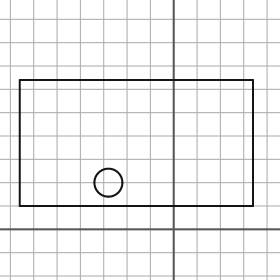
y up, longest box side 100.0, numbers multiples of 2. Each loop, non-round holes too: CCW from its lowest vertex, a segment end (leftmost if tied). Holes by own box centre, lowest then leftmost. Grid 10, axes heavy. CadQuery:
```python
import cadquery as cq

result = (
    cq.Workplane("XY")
    .moveTo(-66.0, 10.0)
    .lineTo(34.0, 10.0)
    .lineTo(34.0, 64.0)
    .lineTo(-66.0, 64.0)
    .close()
    .moveTo(-28.0, 20.0)
    .circle(6.0)
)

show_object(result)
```